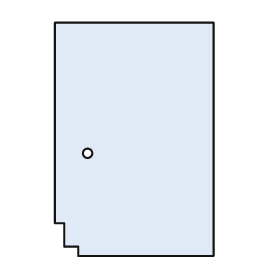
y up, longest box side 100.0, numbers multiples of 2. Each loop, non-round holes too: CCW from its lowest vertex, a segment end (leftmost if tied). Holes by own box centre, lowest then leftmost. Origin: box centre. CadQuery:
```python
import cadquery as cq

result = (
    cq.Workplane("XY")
    .moveTo(-24.0, -50.0)
    .lineTo(34.0, -50.0)
    .lineTo(34.0, 50.0)
    .lineTo(-34.0, 50.0)
    .lineTo(-34.0, -36.0)
    .lineTo(-30.0, -36.0)
    .lineTo(-30.0, -46.0)
    .lineTo(-24.0, -46.0)
    .close()
    .moveTo(-20.0, -6.0)
    .circle(2.0)
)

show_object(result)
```